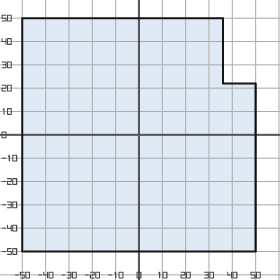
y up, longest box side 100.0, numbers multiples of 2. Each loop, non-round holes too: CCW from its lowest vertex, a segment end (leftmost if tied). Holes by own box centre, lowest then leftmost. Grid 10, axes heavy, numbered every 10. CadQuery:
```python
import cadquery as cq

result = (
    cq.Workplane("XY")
    .moveTo(-50.0, -50.0)
    .lineTo(50.0, -50.0)
    .lineTo(50.0, 22.0)
    .lineTo(36.0, 22.0)
    .lineTo(36.0, 50.0)
    .lineTo(-50.0, 50.0)
    .close()
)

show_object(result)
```